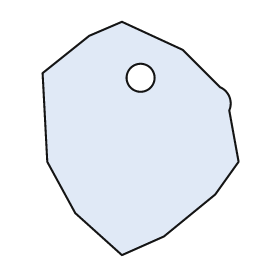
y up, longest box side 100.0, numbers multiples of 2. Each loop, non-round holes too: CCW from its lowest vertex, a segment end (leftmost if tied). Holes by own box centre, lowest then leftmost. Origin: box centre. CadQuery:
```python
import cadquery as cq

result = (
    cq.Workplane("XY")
    .moveTo(-8.0, -50.0)
    .lineTo(10.0, -42.0)
    .lineTo(32.0, -24.0)
    .lineTo(42.0, -10.0)
    .lineTo(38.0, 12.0)
    .threePointArc((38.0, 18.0), (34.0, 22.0))
    .lineTo(18.0, 38.0)
    .lineTo(-8.0, 50.0)
    .lineTo(-22.0, 44.0)
    .lineTo(-42.0, 28.0)
    .lineTo(-40.0, -10.0)
    .lineTo(-28.0, -32.0)
    .close()
    .moveTo(0.0, 26.0)
    .circle(6.0)
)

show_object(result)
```